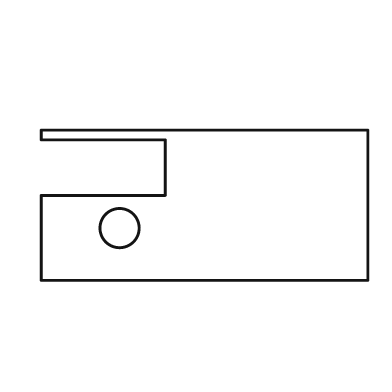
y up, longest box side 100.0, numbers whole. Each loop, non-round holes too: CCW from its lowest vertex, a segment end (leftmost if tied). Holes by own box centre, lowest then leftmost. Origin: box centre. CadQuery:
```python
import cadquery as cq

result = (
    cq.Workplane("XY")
    .moveTo(-50.0, -23.0)
    .lineTo(50.0, -23.0)
    .lineTo(50.0, 23.0)
    .lineTo(-50.0, 23.0)
    .lineTo(-50.0, 20.0)
    .lineTo(-12.0, 20.0)
    .lineTo(-12.0, 3.0)
    .lineTo(-50.0, 3.0)
    .close()
    .moveTo(-26.0, -7.0)
    .circle(6.0)
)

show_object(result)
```